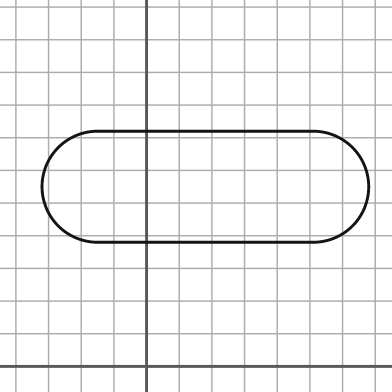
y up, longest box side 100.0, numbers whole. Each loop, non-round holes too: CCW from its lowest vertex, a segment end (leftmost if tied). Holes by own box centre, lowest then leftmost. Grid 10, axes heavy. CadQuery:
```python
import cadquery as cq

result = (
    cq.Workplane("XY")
    .moveTo(-15.0, 38.0)
    .lineTo(51.0, 38.0)
    .threePointArc((68.0, 55.0), (51.0, 72.0))
    .lineTo(-15.0, 72.0)
    .threePointArc((-32.0, 55.0), (-15.0, 38.0))
    .close()
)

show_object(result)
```